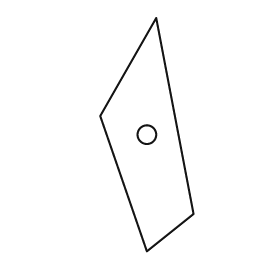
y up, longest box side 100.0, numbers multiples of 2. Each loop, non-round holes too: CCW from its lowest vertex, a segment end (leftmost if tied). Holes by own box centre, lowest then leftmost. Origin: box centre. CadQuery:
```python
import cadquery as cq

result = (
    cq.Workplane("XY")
    .moveTo(0.0, -50.0)
    .lineTo(20.0, -34.0)
    .lineTo(4.0, 50.0)
    .lineTo(-20.0, 8.0)
    .close()
    .moveTo(0.0, 0.0)
    .circle(4.0)
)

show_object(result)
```